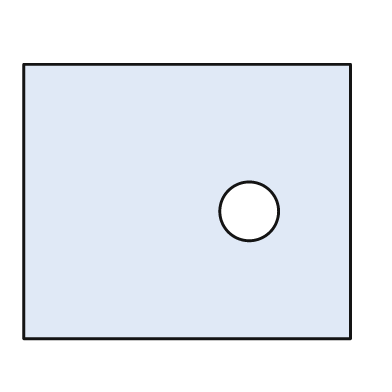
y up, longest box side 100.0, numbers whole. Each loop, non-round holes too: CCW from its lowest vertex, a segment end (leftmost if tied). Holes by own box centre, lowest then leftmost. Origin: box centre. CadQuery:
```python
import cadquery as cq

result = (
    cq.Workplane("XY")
    .moveTo(-50.0, -42.0)
    .lineTo(50.0, -42.0)
    .lineTo(50.0, 42.0)
    .lineTo(-50.0, 42.0)
    .close()
    .moveTo(19.0, -3.0)
    .circle(9.0)
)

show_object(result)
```